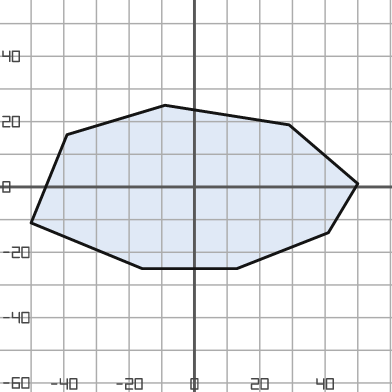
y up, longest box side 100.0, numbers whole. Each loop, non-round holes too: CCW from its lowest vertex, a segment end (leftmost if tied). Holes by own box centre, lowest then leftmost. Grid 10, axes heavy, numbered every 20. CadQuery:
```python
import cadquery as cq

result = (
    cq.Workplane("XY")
    .moveTo(-16.0, -25.0)
    .lineTo(13.0, -25.0)
    .lineTo(41.0, -14.0)
    .lineTo(50.0, 1.0)
    .lineTo(29.0, 19.0)
    .lineTo(-9.0, 25.0)
    .lineTo(-39.0, 16.0)
    .lineTo(-50.0, -11.0)
    .close()
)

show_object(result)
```